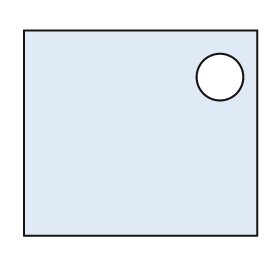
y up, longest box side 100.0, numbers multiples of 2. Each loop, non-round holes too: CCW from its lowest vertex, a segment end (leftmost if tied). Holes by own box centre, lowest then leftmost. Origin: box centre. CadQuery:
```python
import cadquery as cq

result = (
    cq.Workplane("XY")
    .moveTo(-50.0, -44.0)
    .lineTo(50.0, -44.0)
    .lineTo(50.0, 44.0)
    .lineTo(-50.0, 44.0)
    .close()
    .moveTo(34.0, 24.0)
    .circle(10.0)
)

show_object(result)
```